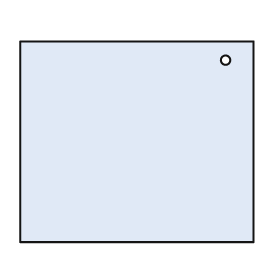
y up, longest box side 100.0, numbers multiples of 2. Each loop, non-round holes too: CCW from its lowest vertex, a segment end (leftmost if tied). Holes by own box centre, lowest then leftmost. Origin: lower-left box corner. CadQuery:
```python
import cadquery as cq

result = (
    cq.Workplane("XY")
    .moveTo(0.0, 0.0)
    .lineTo(100.0, 0.0)
    .lineTo(100.0, 86.0)
    .lineTo(0.0, 86.0)
    .close()
    .moveTo(88.0, 78.0)
    .circle(2.0)
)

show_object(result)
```